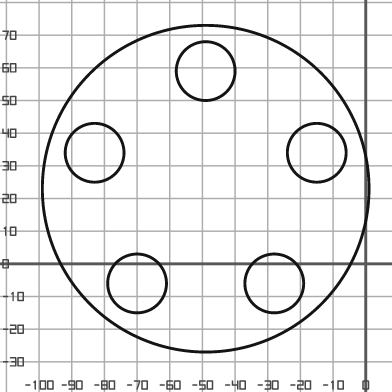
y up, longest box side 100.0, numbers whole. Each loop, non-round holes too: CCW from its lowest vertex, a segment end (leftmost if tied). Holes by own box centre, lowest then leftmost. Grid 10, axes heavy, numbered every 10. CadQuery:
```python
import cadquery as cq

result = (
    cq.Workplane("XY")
    .moveTo(-49.0, 23.0)
    .circle(50.0)
    .moveTo(-70.0, -6.0)
    .circle(9.0)
    .moveTo(-28.0, -6.0)
    .circle(9.0)
    .moveTo(-83.0, 34.0)
    .circle(9.0)
    .moveTo(-15.0, 34.0)
    .circle(9.0)
    .moveTo(-49.0, 59.0)
    .circle(9.0)
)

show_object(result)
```